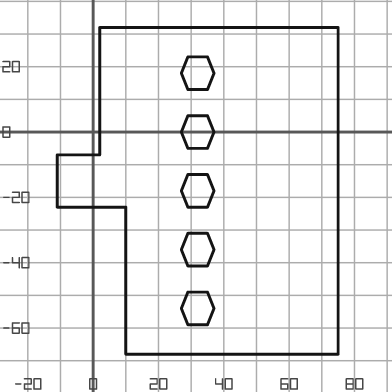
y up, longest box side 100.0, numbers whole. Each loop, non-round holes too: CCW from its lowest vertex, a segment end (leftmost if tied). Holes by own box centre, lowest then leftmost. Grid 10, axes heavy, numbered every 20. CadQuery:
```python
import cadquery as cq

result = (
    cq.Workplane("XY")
    .moveTo(10.0, -68.0)
    .lineTo(75.0, -68.0)
    .lineTo(75.0, 32.0)
    .lineTo(2.0, 32.0)
    .lineTo(2.0, -7.0)
    .lineTo(-11.0, -7.0)
    .lineTo(-11.0, -23.0)
    .lineTo(10.0, -23.0)
    .close()
    .moveTo(29.0, -59.0)
    .lineTo(35.0, -59.0)
    .lineTo(37.0, -54.0)
    .lineTo(35.0, -49.0)
    .lineTo(29.0, -49.0)
    .lineTo(27.0, -54.0)
    .close()
    .moveTo(29.0, -41.0)
    .lineTo(35.0, -41.0)
    .lineTo(37.0, -36.0)
    .lineTo(35.0, -31.0)
    .lineTo(29.0, -31.0)
    .lineTo(27.0, -36.0)
    .close()
    .moveTo(29.0, -23.0)
    .lineTo(35.0, -23.0)
    .lineTo(37.0, -18.0)
    .lineTo(35.0, -13.0)
    .lineTo(29.0, -13.0)
    .lineTo(27.0, -18.0)
    .close()
    .moveTo(29.0, -5.0)
    .lineTo(35.0, -5.0)
    .lineTo(37.0, 0.0)
    .lineTo(35.0, 5.0)
    .lineTo(29.0, 5.0)
    .lineTo(27.0, 0.0)
    .close()
    .moveTo(29.0, 13.0)
    .lineTo(35.0, 13.0)
    .lineTo(37.0, 18.0)
    .lineTo(35.0, 23.0)
    .lineTo(29.0, 23.0)
    .lineTo(27.0, 18.0)
    .close()
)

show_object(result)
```